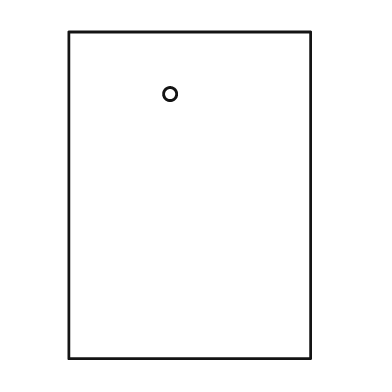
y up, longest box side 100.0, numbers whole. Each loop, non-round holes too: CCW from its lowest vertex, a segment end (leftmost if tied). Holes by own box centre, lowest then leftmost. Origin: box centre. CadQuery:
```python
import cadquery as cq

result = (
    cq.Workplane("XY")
    .moveTo(-37.0, -50.0)
    .lineTo(37.0, -50.0)
    .lineTo(37.0, 50.0)
    .lineTo(-37.0, 50.0)
    .close()
    .moveTo(-6.0, 31.0)
    .circle(2.0)
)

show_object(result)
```